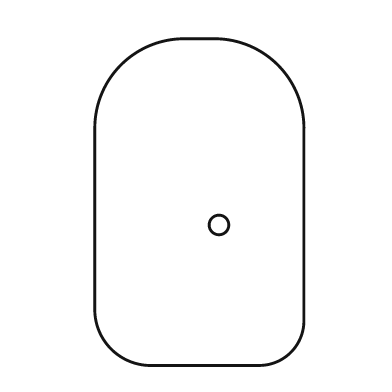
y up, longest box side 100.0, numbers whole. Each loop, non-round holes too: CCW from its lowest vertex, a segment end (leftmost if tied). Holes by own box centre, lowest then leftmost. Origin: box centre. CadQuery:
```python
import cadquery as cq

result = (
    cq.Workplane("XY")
    .moveTo(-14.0, -50.0)
    .lineTo(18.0, -50.0)
    .threePointArc((28.0, -46.0), (32.0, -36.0))
    .lineTo(32.0, 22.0)
    .threePointArc((24.0, 42.0), (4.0, 50.0))
    .lineTo(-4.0, 50.0)
    .threePointArc((-24.0, 42.0), (-32.0, 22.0))
    .lineTo(-32.0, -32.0)
    .threePointArc((-27.0, -45.0), (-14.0, -50.0))
    .close()
    .moveTo(6.0, -7.0)
    .circle(3.0)
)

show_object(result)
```